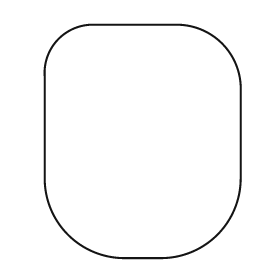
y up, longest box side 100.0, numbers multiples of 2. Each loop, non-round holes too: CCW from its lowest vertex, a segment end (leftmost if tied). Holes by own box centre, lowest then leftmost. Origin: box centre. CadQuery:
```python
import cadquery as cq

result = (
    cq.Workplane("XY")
    .moveTo(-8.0, -50.0)
    .lineTo(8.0, -50.0)
    .threePointArc((32.0, -40.0), (42.0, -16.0))
    .lineTo(42.0, 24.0)
    .threePointArc((34.0, 42.0), (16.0, 50.0))
    .lineTo(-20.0, 50.0)
    .threePointArc((-36.0, 44.0), (-42.0, 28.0))
    .lineTo(-42.0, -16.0)
    .threePointArc((-32.0, -40.0), (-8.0, -50.0))
    .close()
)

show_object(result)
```